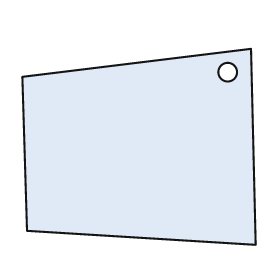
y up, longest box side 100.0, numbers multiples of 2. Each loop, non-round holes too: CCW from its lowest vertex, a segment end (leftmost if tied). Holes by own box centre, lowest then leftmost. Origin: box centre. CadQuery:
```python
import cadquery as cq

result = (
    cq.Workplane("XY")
    .moveTo(50.0, -42.0)
    .lineTo(48.0, 42.0)
    .lineTo(-50.0, 30.0)
    .lineTo(-48.0, -36.0)
    .close()
    .moveTo(38.0, 32.0)
    .circle(4.0)
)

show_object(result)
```